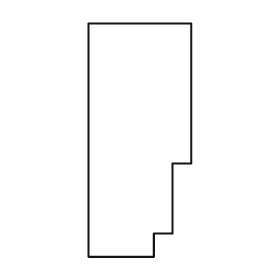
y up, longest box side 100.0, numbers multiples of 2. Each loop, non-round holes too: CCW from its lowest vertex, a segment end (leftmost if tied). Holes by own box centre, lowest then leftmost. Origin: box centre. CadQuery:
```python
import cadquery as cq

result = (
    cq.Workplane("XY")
    .moveTo(-22.0, -50.0)
    .lineTo(6.0, -50.0)
    .lineTo(6.0, -40.0)
    .lineTo(14.0, -40.0)
    .lineTo(14.0, -10.0)
    .lineTo(22.0, -10.0)
    .lineTo(22.0, 50.0)
    .lineTo(-22.0, 50.0)
    .close()
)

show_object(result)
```